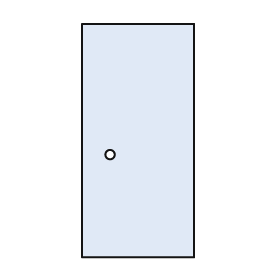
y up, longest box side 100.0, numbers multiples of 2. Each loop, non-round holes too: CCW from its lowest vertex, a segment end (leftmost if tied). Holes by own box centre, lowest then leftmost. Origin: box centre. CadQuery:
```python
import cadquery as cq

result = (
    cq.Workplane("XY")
    .moveTo(-24.0, -50.0)
    .lineTo(24.0, -50.0)
    .lineTo(24.0, 50.0)
    .lineTo(-24.0, 50.0)
    .close()
    .moveTo(-12.0, -6.0)
    .circle(2.0)
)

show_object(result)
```